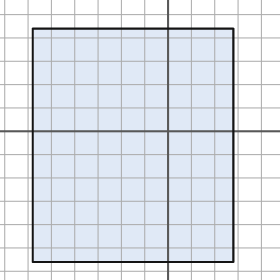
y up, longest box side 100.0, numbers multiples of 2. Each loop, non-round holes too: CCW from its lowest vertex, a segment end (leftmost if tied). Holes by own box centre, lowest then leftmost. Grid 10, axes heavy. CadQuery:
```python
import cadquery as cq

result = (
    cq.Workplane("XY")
    .moveTo(-58.0, -56.0)
    .lineTo(28.0, -56.0)
    .lineTo(28.0, 44.0)
    .lineTo(-58.0, 44.0)
    .close()
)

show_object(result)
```